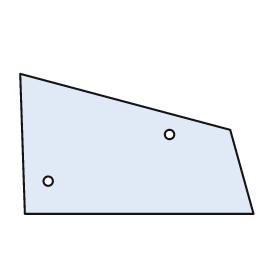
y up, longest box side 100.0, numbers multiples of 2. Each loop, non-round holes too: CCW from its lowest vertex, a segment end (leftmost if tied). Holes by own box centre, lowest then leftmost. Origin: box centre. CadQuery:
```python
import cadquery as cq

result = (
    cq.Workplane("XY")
    .moveTo(-48.0, -30.0)
    .lineTo(50.0, -30.0)
    .lineTo(40.0, 6.0)
    .lineTo(-50.0, 30.0)
    .close()
    .moveTo(-38.0, -16.0)
    .circle(2.0)
    .moveTo(14.0, 4.0)
    .circle(2.0)
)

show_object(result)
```